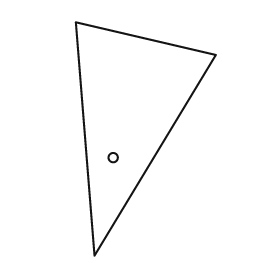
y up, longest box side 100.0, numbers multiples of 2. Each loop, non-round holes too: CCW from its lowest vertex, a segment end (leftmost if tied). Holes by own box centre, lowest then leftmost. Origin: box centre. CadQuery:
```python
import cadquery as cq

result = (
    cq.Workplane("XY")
    .moveTo(-22.0, -50.0)
    .lineTo(30.0, 36.0)
    .lineTo(-30.0, 50.0)
    .close()
    .moveTo(-14.0, -8.0)
    .circle(2.0)
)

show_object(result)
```